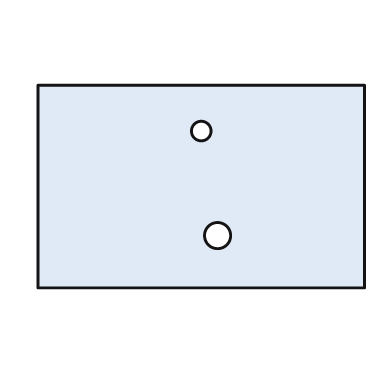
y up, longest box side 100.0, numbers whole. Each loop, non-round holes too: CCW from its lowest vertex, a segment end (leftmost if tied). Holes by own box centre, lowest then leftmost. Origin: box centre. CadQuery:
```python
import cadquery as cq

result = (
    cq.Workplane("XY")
    .moveTo(-50.0, -31.0)
    .lineTo(50.0, -31.0)
    .lineTo(50.0, 31.0)
    .lineTo(-50.0, 31.0)
    .close()
    .moveTo(5.0, -15.0)
    .circle(4.0)
    .moveTo(0.0, 17.0)
    .circle(3.0)
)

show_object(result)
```